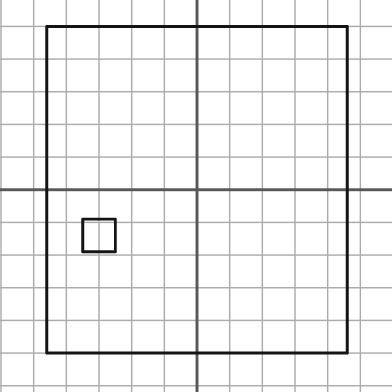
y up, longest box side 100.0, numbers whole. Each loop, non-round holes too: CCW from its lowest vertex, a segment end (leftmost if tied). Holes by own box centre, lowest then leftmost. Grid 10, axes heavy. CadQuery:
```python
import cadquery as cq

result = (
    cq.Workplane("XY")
    .moveTo(-46.0, -50.0)
    .lineTo(46.0, -50.0)
    .lineTo(46.0, 50.0)
    .lineTo(-46.0, 50.0)
    .close()
    .moveTo(-35.0, -19.0)
    .lineTo(-25.0, -19.0)
    .lineTo(-25.0, -9.0)
    .lineTo(-35.0, -9.0)
    .close()
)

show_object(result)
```